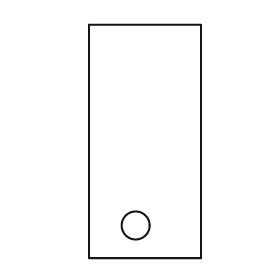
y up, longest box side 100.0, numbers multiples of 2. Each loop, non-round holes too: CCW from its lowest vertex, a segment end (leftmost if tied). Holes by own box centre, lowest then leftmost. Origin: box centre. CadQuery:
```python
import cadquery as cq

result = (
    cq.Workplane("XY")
    .moveTo(-24.0, -50.0)
    .lineTo(24.0, -50.0)
    .lineTo(24.0, 50.0)
    .lineTo(-24.0, 50.0)
    .close()
    .moveTo(-4.0, -36.0)
    .circle(6.0)
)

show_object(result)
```